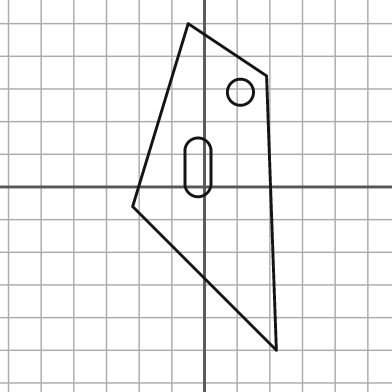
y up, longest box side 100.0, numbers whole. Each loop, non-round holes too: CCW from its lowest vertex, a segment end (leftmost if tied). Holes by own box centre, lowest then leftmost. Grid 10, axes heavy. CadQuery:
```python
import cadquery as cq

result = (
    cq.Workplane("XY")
    .moveTo(22.0, -50.0)
    .lineTo(19.0, 34.0)
    .lineTo(-5.0, 50.0)
    .lineTo(-22.0, -6.0)
    .close()
    .moveTo(-6.0, 1.0)
    .threePointArc((-2.0, -3.0), (2.0, 1.0))
    .lineTo(2.0, 11.0)
    .threePointArc((-2.0, 15.0), (-6.0, 11.0))
    .close()
    .moveTo(11.0, 29.0)
    .circle(4.0)
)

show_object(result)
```